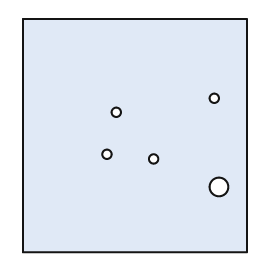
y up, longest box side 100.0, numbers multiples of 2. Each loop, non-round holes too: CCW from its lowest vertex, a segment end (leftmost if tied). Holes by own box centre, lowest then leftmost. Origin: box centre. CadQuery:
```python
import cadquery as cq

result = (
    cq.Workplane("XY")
    .moveTo(-48.0, -50.0)
    .lineTo(48.0, -50.0)
    .lineTo(48.0, 50.0)
    .lineTo(-48.0, 50.0)
    .close()
    .moveTo(36.0, -22.0)
    .circle(4.0)
    .moveTo(8.0, -10.0)
    .circle(2.0)
    .moveTo(-12.0, -8.0)
    .circle(2.0)
    .moveTo(-8.0, 10.0)
    .circle(2.0)
    .moveTo(34.0, 16.0)
    .circle(2.0)
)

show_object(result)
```